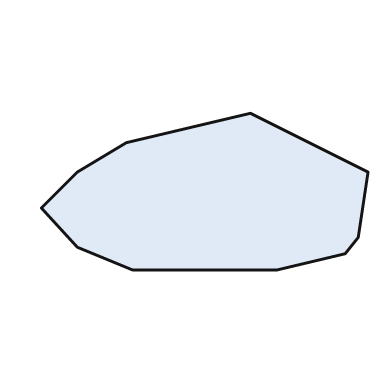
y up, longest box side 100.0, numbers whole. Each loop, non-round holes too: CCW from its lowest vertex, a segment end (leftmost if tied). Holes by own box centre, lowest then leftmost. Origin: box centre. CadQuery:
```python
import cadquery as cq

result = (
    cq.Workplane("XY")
    .moveTo(-22.0, -24.0)
    .lineTo(22.0, -24.0)
    .lineTo(43.0, -19.0)
    .lineTo(47.0, -14.0)
    .lineTo(50.0, 6.0)
    .lineTo(14.0, 24.0)
    .lineTo(-24.0, 15.0)
    .lineTo(-39.0, 6.0)
    .lineTo(-50.0, -5.0)
    .lineTo(-39.0, -17.0)
    .close()
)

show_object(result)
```